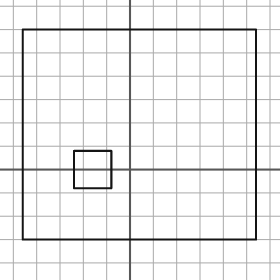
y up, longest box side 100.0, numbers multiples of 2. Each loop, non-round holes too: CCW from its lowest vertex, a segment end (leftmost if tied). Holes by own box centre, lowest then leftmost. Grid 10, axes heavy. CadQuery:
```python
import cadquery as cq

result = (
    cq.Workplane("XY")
    .moveTo(-46.0, -30.0)
    .lineTo(54.0, -30.0)
    .lineTo(54.0, 60.0)
    .lineTo(-46.0, 60.0)
    .close()
    .moveTo(-24.0, -8.0)
    .lineTo(-8.0, -8.0)
    .lineTo(-8.0, 8.0)
    .lineTo(-24.0, 8.0)
    .close()
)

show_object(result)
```